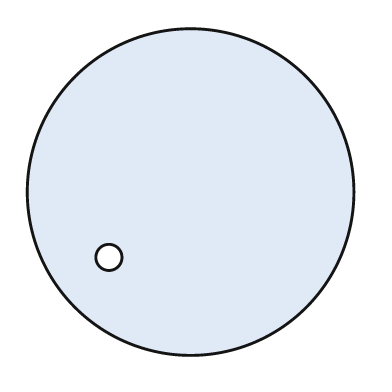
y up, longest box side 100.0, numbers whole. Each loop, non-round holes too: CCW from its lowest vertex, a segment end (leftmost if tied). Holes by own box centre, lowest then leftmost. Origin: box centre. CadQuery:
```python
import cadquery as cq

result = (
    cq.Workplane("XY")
    .moveTo(0.0, 0.0)
    .circle(50.0)
    .moveTo(-25.0, -20.0)
    .circle(4.0)
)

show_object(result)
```